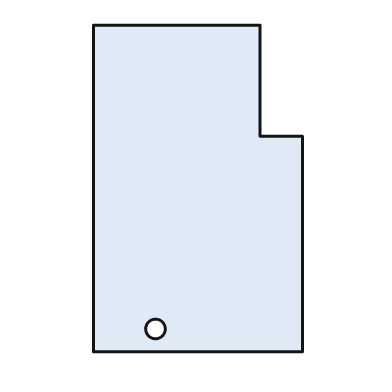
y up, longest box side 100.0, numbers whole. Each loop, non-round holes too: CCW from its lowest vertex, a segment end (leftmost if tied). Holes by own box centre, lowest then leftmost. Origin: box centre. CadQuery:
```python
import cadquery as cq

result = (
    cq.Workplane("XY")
    .moveTo(-32.0, -50.0)
    .lineTo(32.0, -50.0)
    .lineTo(32.0, 16.0)
    .lineTo(19.0, 16.0)
    .lineTo(19.0, 50.0)
    .lineTo(-32.0, 50.0)
    .close()
    .moveTo(-13.0, -43.0)
    .circle(3.0)
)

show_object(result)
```